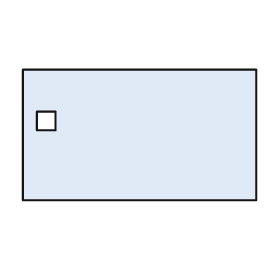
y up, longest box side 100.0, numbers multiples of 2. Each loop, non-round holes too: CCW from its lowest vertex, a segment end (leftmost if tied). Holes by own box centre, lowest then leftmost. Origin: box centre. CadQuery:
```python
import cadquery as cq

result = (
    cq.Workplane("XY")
    .moveTo(-50.0, -28.0)
    .lineTo(50.0, -28.0)
    .lineTo(50.0, 28.0)
    .lineTo(-50.0, 28.0)
    .close()
    .moveTo(-44.0, 2.0)
    .lineTo(-36.0, 2.0)
    .lineTo(-36.0, 10.0)
    .lineTo(-44.0, 10.0)
    .close()
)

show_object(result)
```